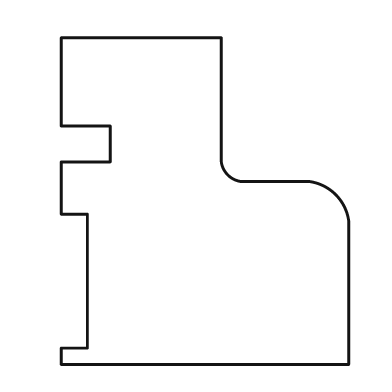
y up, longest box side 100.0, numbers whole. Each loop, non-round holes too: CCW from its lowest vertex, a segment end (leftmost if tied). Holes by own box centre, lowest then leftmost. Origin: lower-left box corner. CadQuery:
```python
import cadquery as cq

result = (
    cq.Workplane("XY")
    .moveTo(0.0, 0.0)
    .lineTo(88.0, 0.0)
    .lineTo(88.0, 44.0)
    .threePointArc((84.0, 52.0), (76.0, 56.0))
    .lineTo(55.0, 56.0)
    .threePointArc((51.0, 58.0), (49.0, 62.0))
    .lineTo(49.0, 100.0)
    .lineTo(0.0, 100.0)
    .lineTo(0.0, 73.0)
    .lineTo(15.0, 73.0)
    .lineTo(15.0, 62.0)
    .lineTo(0.0, 62.0)
    .lineTo(0.0, 46.0)
    .lineTo(8.0, 46.0)
    .lineTo(8.0, 5.0)
    .lineTo(0.0, 5.0)
    .close()
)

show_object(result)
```